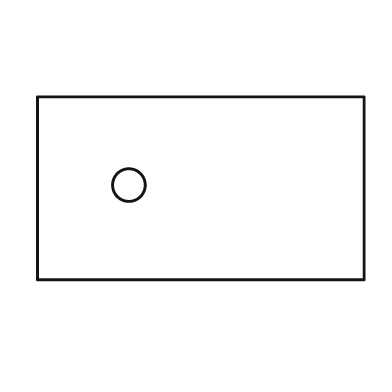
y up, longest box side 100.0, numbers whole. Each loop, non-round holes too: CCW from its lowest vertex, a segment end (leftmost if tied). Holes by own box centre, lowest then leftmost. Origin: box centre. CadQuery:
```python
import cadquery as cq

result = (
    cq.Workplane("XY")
    .moveTo(-50.0, -28.0)
    .lineTo(50.0, -28.0)
    .lineTo(50.0, 28.0)
    .lineTo(-50.0, 28.0)
    .close()
    .moveTo(-22.0, 1.0)
    .circle(5.0)
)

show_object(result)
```